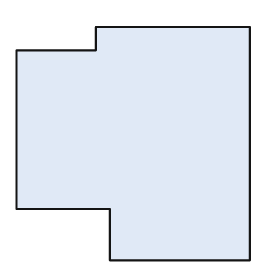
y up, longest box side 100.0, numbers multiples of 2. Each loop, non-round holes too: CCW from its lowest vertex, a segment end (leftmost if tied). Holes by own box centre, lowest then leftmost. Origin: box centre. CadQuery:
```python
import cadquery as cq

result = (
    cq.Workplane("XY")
    .moveTo(-10.0, -50.0)
    .lineTo(50.0, -50.0)
    .lineTo(50.0, 50.0)
    .lineTo(-16.0, 50.0)
    .lineTo(-16.0, 40.0)
    .lineTo(-50.0, 40.0)
    .lineTo(-50.0, -28.0)
    .lineTo(-10.0, -28.0)
    .close()
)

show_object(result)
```